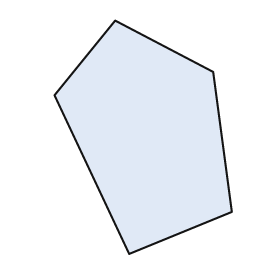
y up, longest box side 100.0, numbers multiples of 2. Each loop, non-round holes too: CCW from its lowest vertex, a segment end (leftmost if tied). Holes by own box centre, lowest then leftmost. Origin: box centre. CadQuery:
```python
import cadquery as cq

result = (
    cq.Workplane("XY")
    .moveTo(-6.0, -50.0)
    .lineTo(38.0, -32.0)
    .lineTo(30.0, 28.0)
    .lineTo(-12.0, 50.0)
    .lineTo(-38.0, 18.0)
    .close()
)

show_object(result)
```